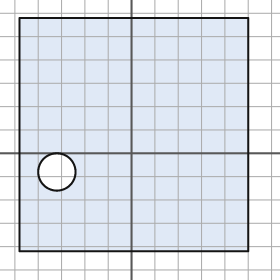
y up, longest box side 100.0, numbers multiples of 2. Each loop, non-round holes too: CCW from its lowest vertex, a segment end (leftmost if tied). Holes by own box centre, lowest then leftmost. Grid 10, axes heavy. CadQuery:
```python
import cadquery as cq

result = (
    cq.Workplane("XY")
    .moveTo(-48.0, -42.0)
    .lineTo(50.0, -42.0)
    .lineTo(50.0, 58.0)
    .lineTo(-48.0, 58.0)
    .close()
    .moveTo(-32.0, -8.0)
    .circle(8.0)
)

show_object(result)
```